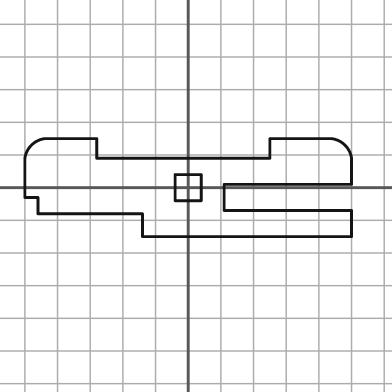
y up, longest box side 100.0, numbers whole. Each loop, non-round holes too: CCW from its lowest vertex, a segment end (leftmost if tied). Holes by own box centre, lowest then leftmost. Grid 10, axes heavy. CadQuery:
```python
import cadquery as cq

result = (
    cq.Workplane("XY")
    .moveTo(-14.0, -15.0)
    .lineTo(50.0, -15.0)
    .lineTo(50.0, -7.0)
    .lineTo(11.0, -7.0)
    .lineTo(11.0, 1.0)
    .lineTo(50.0, 1.0)
    .lineTo(50.0, 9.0)
    .threePointArc((48.0, 13.0), (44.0, 15.0))
    .lineTo(25.0, 15.0)
    .lineTo(25.0, 9.0)
    .lineTo(-28.0, 9.0)
    .lineTo(-28.0, 15.0)
    .lineTo(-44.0, 15.0)
    .threePointArc((-48.0, 13.0), (-50.0, 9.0))
    .lineTo(-50.0, -3.0)
    .lineTo(-46.0, -3.0)
    .lineTo(-46.0, -8.0)
    .lineTo(-14.0, -8.0)
    .close()
    .moveTo(-4.0, -4.0)
    .lineTo(4.0, -4.0)
    .lineTo(4.0, 4.0)
    .lineTo(-4.0, 4.0)
    .close()
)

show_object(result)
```